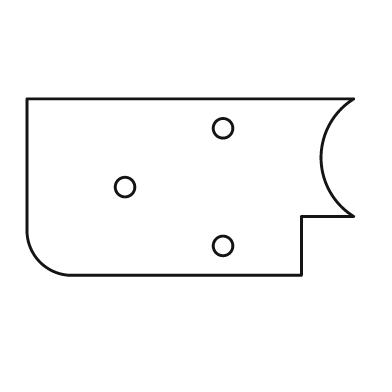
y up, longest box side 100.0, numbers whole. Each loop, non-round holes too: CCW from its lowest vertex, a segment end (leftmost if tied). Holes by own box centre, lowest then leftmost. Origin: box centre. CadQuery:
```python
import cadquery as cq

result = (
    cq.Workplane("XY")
    .moveTo(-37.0, -27.0)
    .lineTo(34.0, -27.0)
    .lineTo(34.0, -9.0)
    .lineTo(50.0, -9.0)
    .threePointArc((40.0, 9.0), (50.0, 27.0))
    .lineTo(-50.0, 27.0)
    .lineTo(-50.0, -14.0)
    .threePointArc((-46.0, -23.0), (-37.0, -27.0))
    .close()
    .moveTo(10.0, -18.0)
    .circle(3.0)
    .moveTo(-20.0, 0.0)
    .circle(3.0)
    .moveTo(10.0, 18.0)
    .circle(3.0)
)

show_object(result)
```